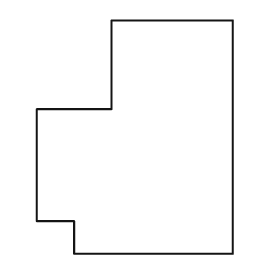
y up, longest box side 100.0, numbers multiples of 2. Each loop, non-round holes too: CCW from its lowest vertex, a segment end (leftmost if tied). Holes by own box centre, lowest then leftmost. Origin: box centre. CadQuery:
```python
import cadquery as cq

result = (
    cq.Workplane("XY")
    .moveTo(-26.0, -50.0)
    .lineTo(42.0, -50.0)
    .lineTo(42.0, 50.0)
    .lineTo(-10.0, 50.0)
    .lineTo(-10.0, 12.0)
    .lineTo(-42.0, 12.0)
    .lineTo(-42.0, -36.0)
    .lineTo(-26.0, -36.0)
    .close()
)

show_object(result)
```